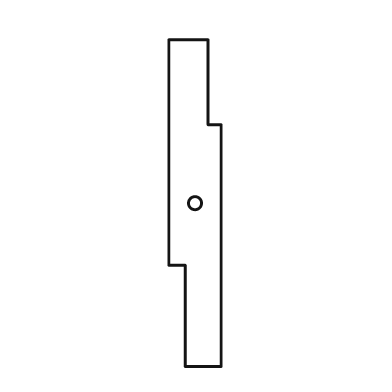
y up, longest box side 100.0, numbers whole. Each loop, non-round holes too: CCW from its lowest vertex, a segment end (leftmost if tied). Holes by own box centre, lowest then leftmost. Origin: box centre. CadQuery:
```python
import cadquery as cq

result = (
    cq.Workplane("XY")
    .moveTo(-3.0, -50.0)
    .lineTo(8.0, -50.0)
    .lineTo(8.0, 24.0)
    .lineTo(4.0, 24.0)
    .lineTo(4.0, 50.0)
    .lineTo(-8.0, 50.0)
    .lineTo(-8.0, -19.0)
    .lineTo(-3.0, -19.0)
    .close()
    .moveTo(0.0, 0.0)
    .circle(2.0)
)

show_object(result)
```